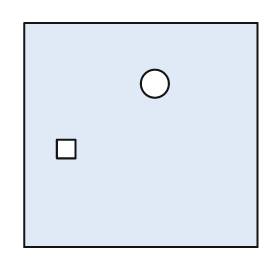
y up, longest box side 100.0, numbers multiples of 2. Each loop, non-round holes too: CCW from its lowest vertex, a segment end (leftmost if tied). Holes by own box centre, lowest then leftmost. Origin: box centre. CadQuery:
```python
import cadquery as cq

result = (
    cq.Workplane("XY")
    .moveTo(-50.0, -48.0)
    .lineTo(50.0, -48.0)
    .lineTo(50.0, 48.0)
    .lineTo(-50.0, 48.0)
    .close()
    .moveTo(-36.0, -10.0)
    .lineTo(-28.0, -10.0)
    .lineTo(-28.0, -2.0)
    .lineTo(-36.0, -2.0)
    .close()
    .moveTo(6.0, 22.0)
    .circle(6.0)
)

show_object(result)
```